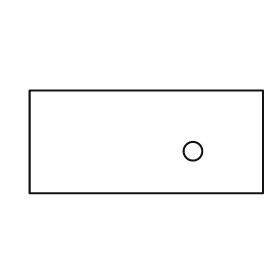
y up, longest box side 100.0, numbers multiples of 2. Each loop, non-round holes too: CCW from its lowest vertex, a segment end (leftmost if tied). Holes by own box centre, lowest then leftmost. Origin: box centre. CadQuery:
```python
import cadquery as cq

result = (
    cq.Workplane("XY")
    .moveTo(-50.0, -22.0)
    .lineTo(50.0, -22.0)
    .lineTo(50.0, 22.0)
    .lineTo(-50.0, 22.0)
    .close()
    .moveTo(20.0, -4.0)
    .circle(4.0)
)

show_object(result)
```